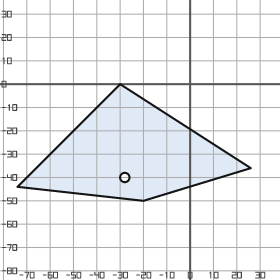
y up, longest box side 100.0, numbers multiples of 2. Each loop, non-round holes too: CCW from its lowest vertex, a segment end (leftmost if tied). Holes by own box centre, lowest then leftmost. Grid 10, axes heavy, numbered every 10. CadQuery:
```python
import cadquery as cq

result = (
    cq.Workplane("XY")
    .moveTo(-20.0, -50.0)
    .lineTo(26.0, -36.0)
    .lineTo(-30.0, 0.0)
    .lineTo(-74.0, -44.0)
    .close()
    .moveTo(-28.0, -40.0)
    .circle(2.0)
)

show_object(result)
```